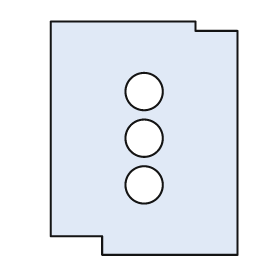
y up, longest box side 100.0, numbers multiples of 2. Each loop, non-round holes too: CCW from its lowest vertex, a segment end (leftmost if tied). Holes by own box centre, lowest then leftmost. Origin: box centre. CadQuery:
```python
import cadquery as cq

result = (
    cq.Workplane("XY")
    .moveTo(-18.0, -50.0)
    .lineTo(40.0, -50.0)
    .lineTo(40.0, 46.0)
    .lineTo(22.0, 46.0)
    .lineTo(22.0, 50.0)
    .lineTo(-40.0, 50.0)
    .lineTo(-40.0, -42.0)
    .lineTo(-18.0, -42.0)
    .close()
    .moveTo(0.0, -20.0)
    .circle(8.0)
    .moveTo(0.0, 0.0)
    .circle(8.0)
    .moveTo(0.0, 20.0)
    .circle(8.0)
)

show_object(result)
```